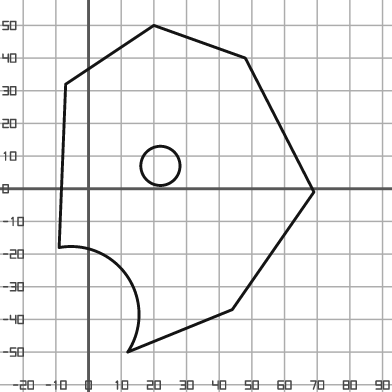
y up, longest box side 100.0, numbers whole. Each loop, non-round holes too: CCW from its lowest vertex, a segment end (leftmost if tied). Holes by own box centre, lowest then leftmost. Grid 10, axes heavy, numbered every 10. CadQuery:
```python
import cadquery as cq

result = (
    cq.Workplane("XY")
    .moveTo(12.0, -50.0)
    .lineTo(44.0, -37.0)
    .lineTo(69.0, -1.0)
    .lineTo(48.0, 40.0)
    .lineTo(20.0, 50.0)
    .lineTo(-7.0, 32.0)
    .lineTo(-9.0, -18.0)
    .threePointArc((12.0, -27.0), (12.0, -50.0))
    .close()
    .moveTo(22.0, 7.0)
    .circle(6.0)
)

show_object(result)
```